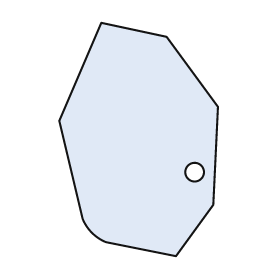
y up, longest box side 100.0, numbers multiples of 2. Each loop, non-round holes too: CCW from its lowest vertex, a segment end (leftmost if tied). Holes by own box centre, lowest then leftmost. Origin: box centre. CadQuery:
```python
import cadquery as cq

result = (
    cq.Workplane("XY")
    .moveTo(16.0, -50.0)
    .lineTo(32.0, -28.0)
    .lineTo(34.0, 14.0)
    .lineTo(12.0, 44.0)
    .lineTo(-16.0, 50.0)
    .lineTo(-34.0, 8.0)
    .lineTo(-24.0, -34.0)
    .threePointArc((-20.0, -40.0), (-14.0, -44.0))
    .close()
    .moveTo(24.0, -14.0)
    .circle(4.0)
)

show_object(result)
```